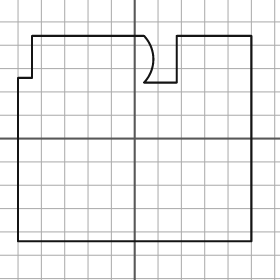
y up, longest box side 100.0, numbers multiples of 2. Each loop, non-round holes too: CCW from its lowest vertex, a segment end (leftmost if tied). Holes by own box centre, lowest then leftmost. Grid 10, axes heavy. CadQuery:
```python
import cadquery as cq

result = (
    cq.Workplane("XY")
    .moveTo(-50.0, -44.0)
    .lineTo(50.0, -44.0)
    .lineTo(50.0, 44.0)
    .lineTo(18.0, 44.0)
    .lineTo(18.0, 24.0)
    .lineTo(4.0, 24.0)
    .threePointArc((8.0, 34.0), (4.0, 44.0))
    .lineTo(-44.0, 44.0)
    .lineTo(-44.0, 26.0)
    .lineTo(-50.0, 26.0)
    .close()
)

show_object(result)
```